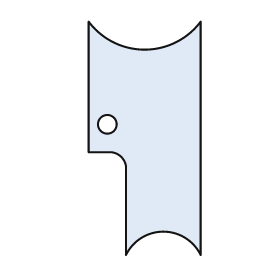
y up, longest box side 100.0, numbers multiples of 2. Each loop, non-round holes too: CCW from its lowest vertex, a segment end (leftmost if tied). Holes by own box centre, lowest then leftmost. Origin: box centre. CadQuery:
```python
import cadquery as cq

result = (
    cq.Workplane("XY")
    .moveTo(-8.0, -50.0)
    .threePointArc((8.0, -40.0), (24.0, -50.0))
    .lineTo(24.0, 50.0)
    .threePointArc((0.0, 38.0), (-24.0, 50.0))
    .lineTo(-24.0, -6.0)
    .lineTo(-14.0, -6.0)
    .threePointArc((-10.0, -8.0), (-8.0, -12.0))
    .close()
    .moveTo(-16.0, 6.0)
    .circle(4.0)
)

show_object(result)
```